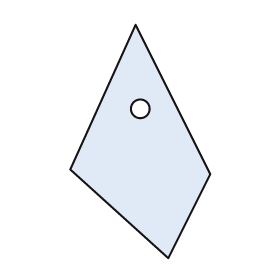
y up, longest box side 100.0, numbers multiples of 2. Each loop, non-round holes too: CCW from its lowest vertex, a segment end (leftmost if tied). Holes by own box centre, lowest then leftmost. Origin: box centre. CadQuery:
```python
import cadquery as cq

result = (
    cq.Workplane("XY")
    .moveTo(12.0, -50.0)
    .lineTo(30.0, -14.0)
    .lineTo(-2.0, 50.0)
    .lineTo(-30.0, -12.0)
    .close()
    .moveTo(0.0, 14.0)
    .circle(4.0)
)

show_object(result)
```